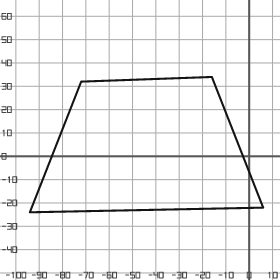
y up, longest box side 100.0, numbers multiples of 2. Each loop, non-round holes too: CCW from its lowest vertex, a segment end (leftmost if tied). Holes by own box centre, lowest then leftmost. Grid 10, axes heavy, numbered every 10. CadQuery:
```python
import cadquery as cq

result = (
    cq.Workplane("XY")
    .moveTo(-94.0, -24.0)
    .lineTo(6.0, -22.0)
    .lineTo(-16.0, 34.0)
    .lineTo(-72.0, 32.0)
    .close()
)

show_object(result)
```